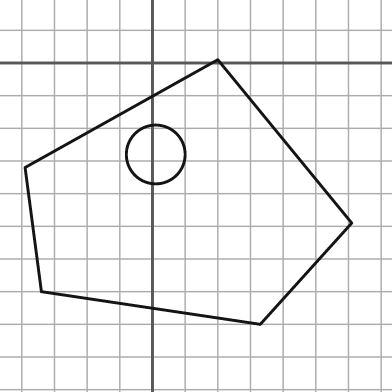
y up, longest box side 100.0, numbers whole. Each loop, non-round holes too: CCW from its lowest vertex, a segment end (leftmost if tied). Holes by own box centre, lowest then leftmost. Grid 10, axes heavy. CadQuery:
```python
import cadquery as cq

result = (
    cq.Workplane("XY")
    .moveTo(33.0, -80.0)
    .lineTo(61.0, -49.0)
    .lineTo(20.0, 1.0)
    .lineTo(-39.0, -32.0)
    .lineTo(-34.0, -70.0)
    .close()
    .moveTo(1.0, -28.0)
    .circle(9.0)
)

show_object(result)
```